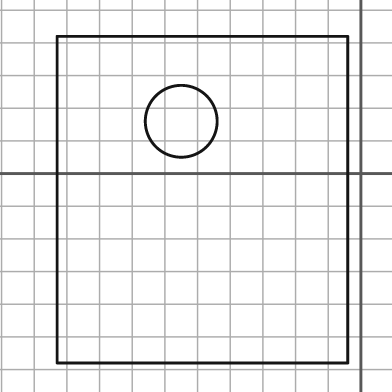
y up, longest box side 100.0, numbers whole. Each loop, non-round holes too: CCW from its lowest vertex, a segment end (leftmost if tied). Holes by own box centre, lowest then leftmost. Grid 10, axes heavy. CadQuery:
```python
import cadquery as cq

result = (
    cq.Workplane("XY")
    .moveTo(-93.0, -58.0)
    .lineTo(-4.0, -58.0)
    .lineTo(-4.0, 42.0)
    .lineTo(-93.0, 42.0)
    .close()
    .moveTo(-55.0, 16.0)
    .circle(11.0)
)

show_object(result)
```